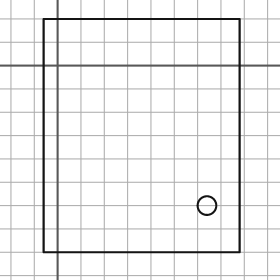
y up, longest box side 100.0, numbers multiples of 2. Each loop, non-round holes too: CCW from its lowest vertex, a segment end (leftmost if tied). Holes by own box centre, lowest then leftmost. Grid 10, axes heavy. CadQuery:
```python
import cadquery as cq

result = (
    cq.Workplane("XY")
    .moveTo(-6.0, -80.0)
    .lineTo(78.0, -80.0)
    .lineTo(78.0, 20.0)
    .lineTo(-6.0, 20.0)
    .close()
    .moveTo(64.0, -60.0)
    .circle(4.0)
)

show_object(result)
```